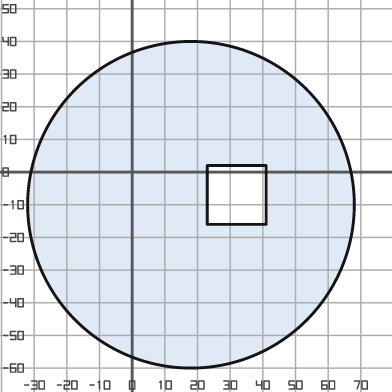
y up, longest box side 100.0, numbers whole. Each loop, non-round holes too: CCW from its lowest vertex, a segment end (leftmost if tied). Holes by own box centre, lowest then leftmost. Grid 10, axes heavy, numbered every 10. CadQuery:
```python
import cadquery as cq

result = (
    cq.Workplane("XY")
    .moveTo(18.0, -10.0)
    .circle(50.0)
    .moveTo(23.0, -16.0)
    .lineTo(41.0, -16.0)
    .lineTo(41.0, 2.0)
    .lineTo(23.0, 2.0)
    .close()
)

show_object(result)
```